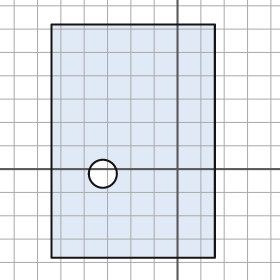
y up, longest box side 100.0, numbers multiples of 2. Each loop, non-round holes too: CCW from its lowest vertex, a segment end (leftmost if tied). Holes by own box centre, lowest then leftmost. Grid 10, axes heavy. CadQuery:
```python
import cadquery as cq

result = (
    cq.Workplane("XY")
    .moveTo(-54.0, -38.0)
    .lineTo(16.0, -38.0)
    .lineTo(16.0, 62.0)
    .lineTo(-54.0, 62.0)
    .close()
    .moveTo(-32.0, -2.0)
    .circle(6.0)
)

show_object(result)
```